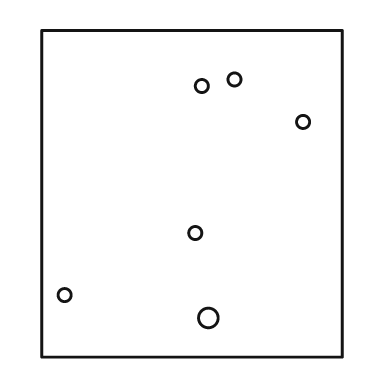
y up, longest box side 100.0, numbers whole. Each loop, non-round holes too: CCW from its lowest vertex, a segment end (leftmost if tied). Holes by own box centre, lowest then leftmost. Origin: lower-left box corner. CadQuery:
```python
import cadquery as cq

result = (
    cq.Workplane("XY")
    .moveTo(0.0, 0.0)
    .lineTo(92.0, 0.0)
    .lineTo(92.0, 100.0)
    .lineTo(0.0, 100.0)
    .close()
    .moveTo(51.0, 12.0)
    .circle(3.0)
    .moveTo(7.0, 19.0)
    .circle(2.0)
    .moveTo(47.0, 38.0)
    .circle(2.0)
    .moveTo(80.0, 72.0)
    .circle(2.0)
    .moveTo(49.0, 83.0)
    .circle(2.0)
    .moveTo(59.0, 85.0)
    .circle(2.0)
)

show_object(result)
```